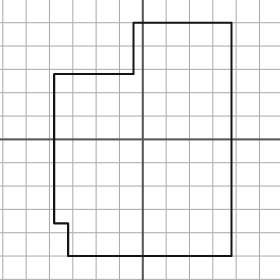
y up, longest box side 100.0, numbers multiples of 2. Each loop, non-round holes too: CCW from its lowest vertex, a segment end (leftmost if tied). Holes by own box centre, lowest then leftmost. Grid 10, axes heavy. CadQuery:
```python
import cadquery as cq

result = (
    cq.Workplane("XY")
    .moveTo(-32.0, -50.0)
    .lineTo(38.0, -50.0)
    .lineTo(38.0, 50.0)
    .lineTo(-4.0, 50.0)
    .lineTo(-4.0, 28.0)
    .lineTo(-38.0, 28.0)
    .lineTo(-38.0, -36.0)
    .lineTo(-32.0, -36.0)
    .close()
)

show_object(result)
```